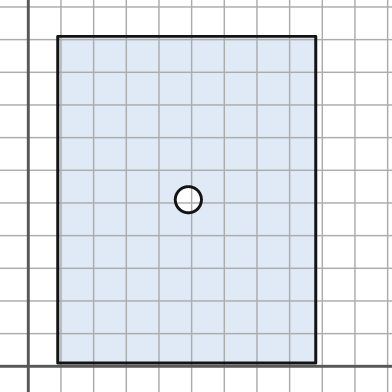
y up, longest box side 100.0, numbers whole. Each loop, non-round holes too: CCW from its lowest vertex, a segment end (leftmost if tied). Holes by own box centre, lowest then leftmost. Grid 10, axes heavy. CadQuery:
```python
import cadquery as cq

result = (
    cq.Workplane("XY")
    .moveTo(9.0, 1.0)
    .lineTo(88.0, 1.0)
    .lineTo(88.0, 101.0)
    .lineTo(9.0, 101.0)
    .close()
    .moveTo(49.0, 51.0)
    .circle(4.0)
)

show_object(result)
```